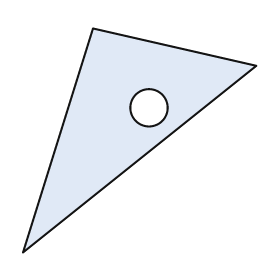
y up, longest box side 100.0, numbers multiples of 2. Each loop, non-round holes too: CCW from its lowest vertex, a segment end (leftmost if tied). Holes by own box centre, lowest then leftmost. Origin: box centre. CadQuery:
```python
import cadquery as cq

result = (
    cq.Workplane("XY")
    .moveTo(-50.0, -48.0)
    .lineTo(50.0, 32.0)
    .lineTo(-20.0, 48.0)
    .close()
    .moveTo(4.0, 14.0)
    .circle(8.0)
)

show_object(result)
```